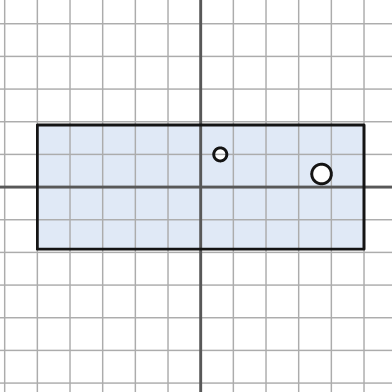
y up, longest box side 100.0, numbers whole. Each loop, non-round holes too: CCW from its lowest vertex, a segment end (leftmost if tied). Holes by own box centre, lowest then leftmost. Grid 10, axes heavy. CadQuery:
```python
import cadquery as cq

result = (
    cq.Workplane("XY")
    .moveTo(-50.0, -19.0)
    .lineTo(50.0, -19.0)
    .lineTo(50.0, 19.0)
    .lineTo(-50.0, 19.0)
    .close()
    .moveTo(37.0, 4.0)
    .circle(3.0)
    .moveTo(6.0, 10.0)
    .circle(2.0)
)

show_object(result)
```